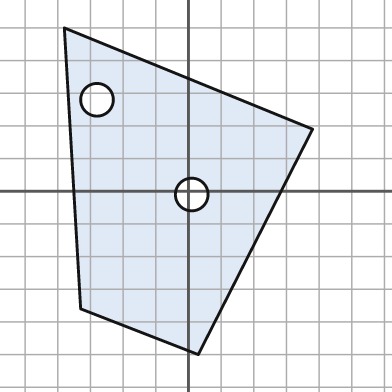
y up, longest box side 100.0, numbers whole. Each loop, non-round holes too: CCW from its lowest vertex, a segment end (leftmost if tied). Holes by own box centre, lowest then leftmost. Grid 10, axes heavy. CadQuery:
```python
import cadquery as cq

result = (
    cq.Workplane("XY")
    .moveTo(3.0, -50.0)
    .lineTo(38.0, 19.0)
    .lineTo(-38.0, 50.0)
    .lineTo(-33.0, -36.0)
    .close()
    .moveTo(1.0, -1.0)
    .circle(5.0)
    .moveTo(-28.0, 28.0)
    .circle(5.0)
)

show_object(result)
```